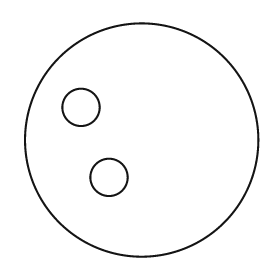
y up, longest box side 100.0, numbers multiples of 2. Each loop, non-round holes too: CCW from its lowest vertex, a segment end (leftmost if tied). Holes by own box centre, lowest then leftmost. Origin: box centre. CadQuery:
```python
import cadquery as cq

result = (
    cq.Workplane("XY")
    .moveTo(0.0, 0.0)
    .circle(50.0)
    .moveTo(-14.0, -16.0)
    .circle(8.0)
    .moveTo(-26.0, 14.0)
    .circle(8.0)
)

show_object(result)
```